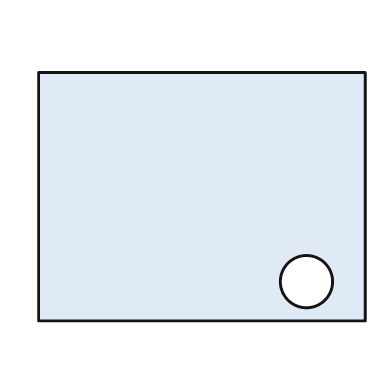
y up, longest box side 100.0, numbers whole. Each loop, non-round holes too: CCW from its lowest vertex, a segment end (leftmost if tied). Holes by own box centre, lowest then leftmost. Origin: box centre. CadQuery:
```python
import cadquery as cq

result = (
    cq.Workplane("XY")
    .moveTo(-50.0, -38.0)
    .lineTo(50.0, -38.0)
    .lineTo(50.0, 38.0)
    .lineTo(-50.0, 38.0)
    .close()
    .moveTo(32.0, -26.0)
    .circle(8.0)
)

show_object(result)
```